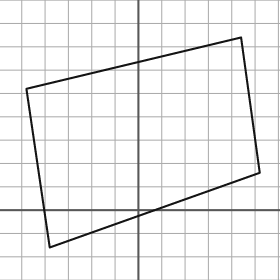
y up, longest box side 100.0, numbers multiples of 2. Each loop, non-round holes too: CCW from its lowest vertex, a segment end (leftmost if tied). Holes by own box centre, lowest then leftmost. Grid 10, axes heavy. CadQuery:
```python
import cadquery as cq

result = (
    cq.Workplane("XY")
    .moveTo(-38.0, -16.0)
    .lineTo(52.0, 16.0)
    .lineTo(44.0, 74.0)
    .lineTo(-48.0, 52.0)
    .close()
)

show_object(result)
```